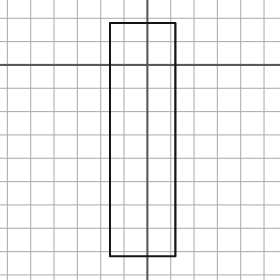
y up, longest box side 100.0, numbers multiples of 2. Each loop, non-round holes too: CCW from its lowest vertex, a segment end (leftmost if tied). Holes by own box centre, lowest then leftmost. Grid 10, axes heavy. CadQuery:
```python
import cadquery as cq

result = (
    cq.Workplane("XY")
    .moveTo(-16.0, -82.0)
    .lineTo(12.0, -82.0)
    .lineTo(12.0, 18.0)
    .lineTo(-16.0, 18.0)
    .close()
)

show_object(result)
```